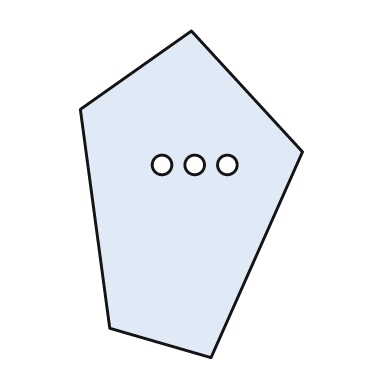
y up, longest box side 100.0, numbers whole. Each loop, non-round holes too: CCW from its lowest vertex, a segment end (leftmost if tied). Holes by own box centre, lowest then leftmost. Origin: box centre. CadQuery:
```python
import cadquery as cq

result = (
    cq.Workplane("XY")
    .moveTo(6.0, -50.0)
    .lineTo(34.0, 13.0)
    .lineTo(0.0, 50.0)
    .lineTo(-34.0, 26.0)
    .lineTo(-25.0, -41.0)
    .close()
    .moveTo(-9.0, 9.0)
    .circle(3.0)
    .moveTo(1.0, 9.0)
    .circle(3.0)
    .moveTo(11.0, 9.0)
    .circle(3.0)
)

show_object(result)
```